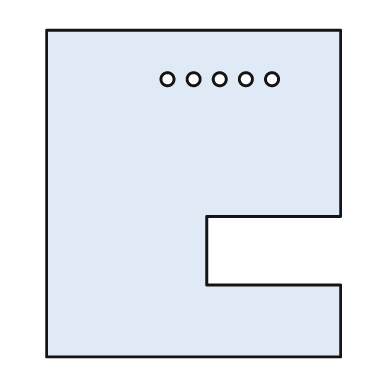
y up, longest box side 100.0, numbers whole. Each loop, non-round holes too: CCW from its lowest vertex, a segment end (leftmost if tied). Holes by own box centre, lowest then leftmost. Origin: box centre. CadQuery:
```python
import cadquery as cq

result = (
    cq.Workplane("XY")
    .moveTo(-45.0, -50.0)
    .lineTo(45.0, -50.0)
    .lineTo(45.0, -28.0)
    .lineTo(4.0, -28.0)
    .lineTo(4.0, -7.0)
    .lineTo(45.0, -7.0)
    .lineTo(45.0, 50.0)
    .lineTo(-45.0, 50.0)
    .close()
    .moveTo(-8.0, 35.0)
    .circle(2.0)
    .moveTo(0.0, 35.0)
    .circle(2.0)
    .moveTo(8.0, 35.0)
    .circle(2.0)
    .moveTo(16.0, 35.0)
    .circle(2.0)
    .moveTo(24.0, 35.0)
    .circle(2.0)
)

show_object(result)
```